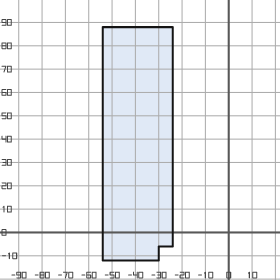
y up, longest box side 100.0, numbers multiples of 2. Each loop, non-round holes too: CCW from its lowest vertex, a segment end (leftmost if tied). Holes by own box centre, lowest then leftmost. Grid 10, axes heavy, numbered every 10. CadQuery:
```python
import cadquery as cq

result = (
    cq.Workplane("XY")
    .moveTo(-54.0, -12.0)
    .lineTo(-30.0, -12.0)
    .lineTo(-30.0, -6.0)
    .lineTo(-24.0, -6.0)
    .lineTo(-24.0, 88.0)
    .lineTo(-54.0, 88.0)
    .close()
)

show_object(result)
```